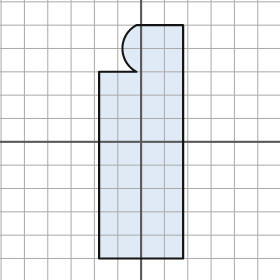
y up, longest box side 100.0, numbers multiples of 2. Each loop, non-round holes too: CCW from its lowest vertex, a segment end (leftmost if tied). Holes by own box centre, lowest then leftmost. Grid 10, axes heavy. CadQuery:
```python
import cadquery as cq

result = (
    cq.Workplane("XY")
    .moveTo(-18.0, -50.0)
    .lineTo(18.0, -50.0)
    .lineTo(18.0, 50.0)
    .lineTo(-2.0, 50.0)
    .threePointArc((-8.0, 40.0), (-2.0, 30.0))
    .lineTo(-18.0, 30.0)
    .close()
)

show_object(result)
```